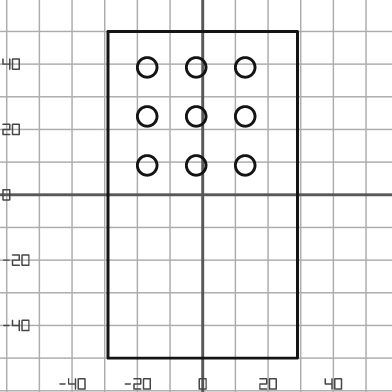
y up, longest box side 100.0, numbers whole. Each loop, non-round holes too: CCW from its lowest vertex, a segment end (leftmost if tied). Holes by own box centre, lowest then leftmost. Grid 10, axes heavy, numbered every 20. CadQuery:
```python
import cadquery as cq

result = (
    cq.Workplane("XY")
    .moveTo(-29.0, -50.0)
    .lineTo(29.0, -50.0)
    .lineTo(29.0, 50.0)
    .lineTo(-29.0, 50.0)
    .close()
    .moveTo(-17.0, 9.0)
    .circle(3.0)
    .moveTo(-2.0, 9.0)
    .circle(3.0)
    .moveTo(13.0, 9.0)
    .circle(3.0)
    .moveTo(-17.0, 24.0)
    .circle(3.0)
    .moveTo(-2.0, 24.0)
    .circle(3.0)
    .moveTo(13.0, 24.0)
    .circle(3.0)
    .moveTo(-17.0, 39.0)
    .circle(3.0)
    .moveTo(-2.0, 39.0)
    .circle(3.0)
    .moveTo(13.0, 39.0)
    .circle(3.0)
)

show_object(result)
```